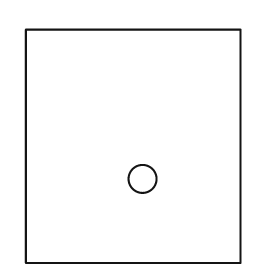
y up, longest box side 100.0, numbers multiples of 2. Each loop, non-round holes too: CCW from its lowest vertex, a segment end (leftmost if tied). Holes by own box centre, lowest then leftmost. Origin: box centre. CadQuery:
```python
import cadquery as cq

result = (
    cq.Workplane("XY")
    .moveTo(-46.0, -50.0)
    .lineTo(46.0, -50.0)
    .lineTo(46.0, 50.0)
    .lineTo(-46.0, 50.0)
    .close()
    .moveTo(4.0, -14.0)
    .circle(6.0)
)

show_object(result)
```